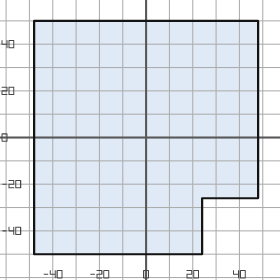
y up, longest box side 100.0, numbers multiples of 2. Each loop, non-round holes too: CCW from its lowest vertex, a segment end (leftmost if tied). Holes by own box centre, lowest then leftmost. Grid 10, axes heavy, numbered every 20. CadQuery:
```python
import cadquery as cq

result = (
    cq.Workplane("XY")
    .moveTo(-48.0, -50.0)
    .lineTo(24.0, -50.0)
    .lineTo(24.0, -26.0)
    .lineTo(48.0, -26.0)
    .lineTo(48.0, 50.0)
    .lineTo(-48.0, 50.0)
    .close()
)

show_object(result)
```